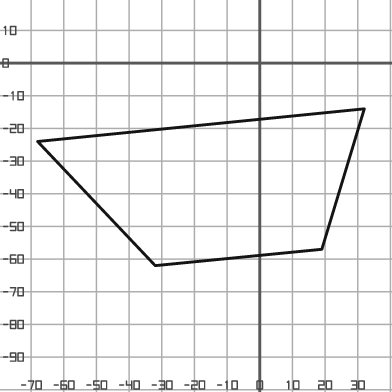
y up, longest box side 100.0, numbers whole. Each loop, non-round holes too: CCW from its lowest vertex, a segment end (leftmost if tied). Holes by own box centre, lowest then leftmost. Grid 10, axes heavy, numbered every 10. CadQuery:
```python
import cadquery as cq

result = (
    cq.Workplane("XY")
    .moveTo(-32.0, -62.0)
    .lineTo(19.0, -57.0)
    .lineTo(32.0, -14.0)
    .lineTo(-68.0, -24.0)
    .close()
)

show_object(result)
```